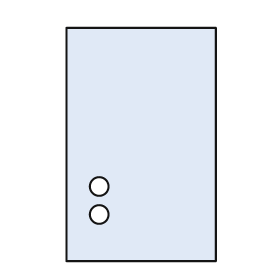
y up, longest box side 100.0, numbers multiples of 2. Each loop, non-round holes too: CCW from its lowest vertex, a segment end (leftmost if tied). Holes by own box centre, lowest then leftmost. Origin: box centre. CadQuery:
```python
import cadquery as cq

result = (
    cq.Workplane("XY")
    .moveTo(-32.0, -50.0)
    .lineTo(32.0, -50.0)
    .lineTo(32.0, 50.0)
    .lineTo(-32.0, 50.0)
    .close()
    .moveTo(-18.0, -30.0)
    .circle(4.0)
    .moveTo(-18.0, -18.0)
    .circle(4.0)
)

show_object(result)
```